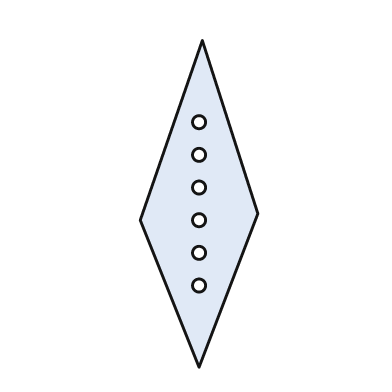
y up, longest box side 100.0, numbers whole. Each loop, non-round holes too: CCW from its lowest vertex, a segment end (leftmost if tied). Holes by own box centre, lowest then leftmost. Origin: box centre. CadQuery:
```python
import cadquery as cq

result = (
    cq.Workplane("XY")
    .moveTo(0.0, -50.0)
    .lineTo(18.0, -3.0)
    .lineTo(1.0, 50.0)
    .lineTo(-18.0, -5.0)
    .close()
    .moveTo(0.0, -25.0)
    .circle(2.0)
    .moveTo(0.0, -15.0)
    .circle(2.0)
    .moveTo(0.0, -5.0)
    .circle(2.0)
    .moveTo(0.0, 5.0)
    .circle(2.0)
    .moveTo(0.0, 15.0)
    .circle(2.0)
    .moveTo(0.0, 25.0)
    .circle(2.0)
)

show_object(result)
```